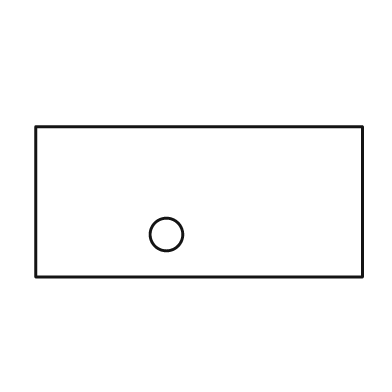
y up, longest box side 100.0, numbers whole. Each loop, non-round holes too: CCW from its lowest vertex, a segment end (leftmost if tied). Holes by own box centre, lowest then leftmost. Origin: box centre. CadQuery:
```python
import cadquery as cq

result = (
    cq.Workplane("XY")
    .moveTo(-50.0, -23.0)
    .lineTo(50.0, -23.0)
    .lineTo(50.0, 23.0)
    .lineTo(-50.0, 23.0)
    .close()
    .moveTo(-10.0, -10.0)
    .circle(5.0)
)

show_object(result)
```